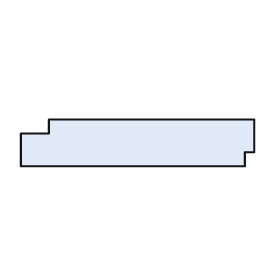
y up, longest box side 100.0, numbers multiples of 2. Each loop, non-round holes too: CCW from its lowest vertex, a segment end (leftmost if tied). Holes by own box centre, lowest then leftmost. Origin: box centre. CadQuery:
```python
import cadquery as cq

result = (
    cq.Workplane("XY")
    .moveTo(-50.0, -10.0)
    .lineTo(46.0, -10.0)
    .lineTo(46.0, -4.0)
    .lineTo(50.0, -4.0)
    .lineTo(50.0, 10.0)
    .lineTo(-38.0, 10.0)
    .lineTo(-38.0, 4.0)
    .lineTo(-50.0, 4.0)
    .close()
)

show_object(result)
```